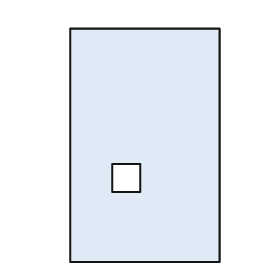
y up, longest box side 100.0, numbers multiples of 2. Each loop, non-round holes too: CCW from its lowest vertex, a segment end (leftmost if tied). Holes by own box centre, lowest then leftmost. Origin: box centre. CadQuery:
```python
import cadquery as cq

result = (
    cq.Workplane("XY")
    .moveTo(-32.0, -50.0)
    .lineTo(32.0, -50.0)
    .lineTo(32.0, 50.0)
    .lineTo(-32.0, 50.0)
    .close()
    .moveTo(-14.0, -20.0)
    .lineTo(-2.0, -20.0)
    .lineTo(-2.0, -8.0)
    .lineTo(-14.0, -8.0)
    .close()
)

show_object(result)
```